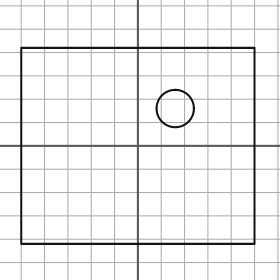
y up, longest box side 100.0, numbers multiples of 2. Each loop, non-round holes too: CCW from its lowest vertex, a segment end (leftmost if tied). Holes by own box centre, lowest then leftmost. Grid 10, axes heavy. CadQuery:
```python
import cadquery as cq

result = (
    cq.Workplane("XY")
    .moveTo(-50.0, -42.0)
    .lineTo(50.0, -42.0)
    .lineTo(50.0, 42.0)
    .lineTo(-50.0, 42.0)
    .close()
    .moveTo(16.0, 16.0)
    .circle(8.0)
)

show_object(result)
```